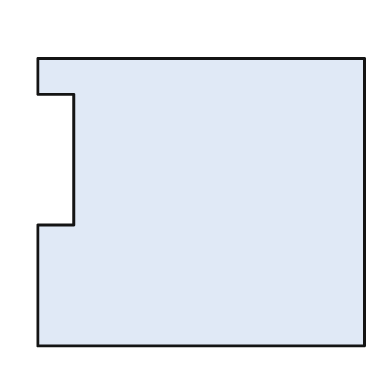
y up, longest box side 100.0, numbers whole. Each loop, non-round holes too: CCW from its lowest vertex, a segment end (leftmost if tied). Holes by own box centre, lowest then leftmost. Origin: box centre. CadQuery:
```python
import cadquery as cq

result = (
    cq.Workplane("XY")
    .moveTo(-50.0, -44.0)
    .lineTo(50.0, -44.0)
    .lineTo(50.0, 44.0)
    .lineTo(-50.0, 44.0)
    .lineTo(-50.0, 33.0)
    .lineTo(-39.0, 33.0)
    .lineTo(-39.0, -7.0)
    .lineTo(-50.0, -7.0)
    .close()
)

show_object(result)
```